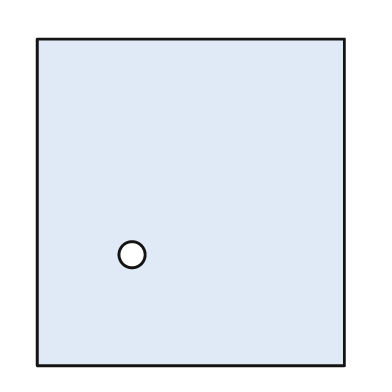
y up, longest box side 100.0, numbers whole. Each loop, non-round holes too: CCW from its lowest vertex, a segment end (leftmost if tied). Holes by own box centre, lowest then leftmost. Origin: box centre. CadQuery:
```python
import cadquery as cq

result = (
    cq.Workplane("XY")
    .moveTo(-47.0, -50.0)
    .lineTo(47.0, -50.0)
    .lineTo(47.0, 50.0)
    .lineTo(-47.0, 50.0)
    .close()
    .moveTo(-18.0, -16.0)
    .circle(4.0)
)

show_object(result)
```